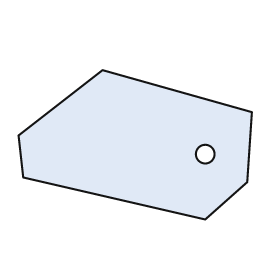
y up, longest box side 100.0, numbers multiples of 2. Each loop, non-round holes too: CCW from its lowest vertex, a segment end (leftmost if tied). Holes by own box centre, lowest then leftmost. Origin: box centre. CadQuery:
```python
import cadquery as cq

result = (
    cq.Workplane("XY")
    .moveTo(30.0, -32.0)
    .lineTo(48.0, -16.0)
    .lineTo(50.0, 14.0)
    .lineTo(-14.0, 32.0)
    .lineTo(-50.0, 4.0)
    .lineTo(-48.0, -14.0)
    .close()
    .moveTo(30.0, -4.0)
    .circle(4.0)
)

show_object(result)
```